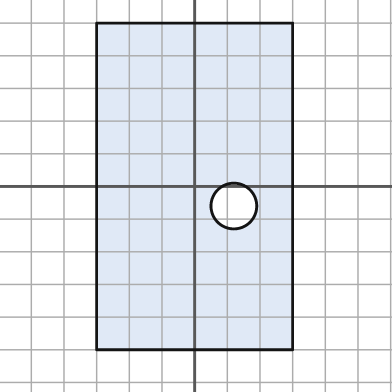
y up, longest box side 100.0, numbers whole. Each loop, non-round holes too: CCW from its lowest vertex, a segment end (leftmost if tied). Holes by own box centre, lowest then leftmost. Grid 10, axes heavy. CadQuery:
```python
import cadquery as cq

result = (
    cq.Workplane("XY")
    .moveTo(-30.0, -50.0)
    .lineTo(30.0, -50.0)
    .lineTo(30.0, 50.0)
    .lineTo(-30.0, 50.0)
    .close()
    .moveTo(12.0, -6.0)
    .circle(7.0)
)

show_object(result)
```